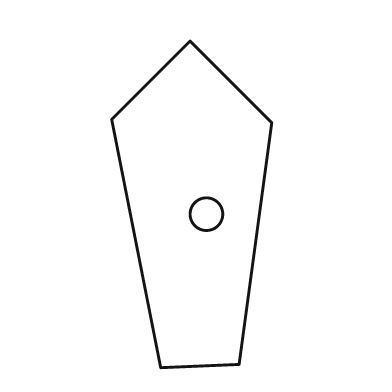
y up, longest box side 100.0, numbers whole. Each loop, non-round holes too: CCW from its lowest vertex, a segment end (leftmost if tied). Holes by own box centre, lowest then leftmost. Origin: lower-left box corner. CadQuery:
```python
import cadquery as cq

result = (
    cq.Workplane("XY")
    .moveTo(15.0, 0.0)
    .lineTo(39.0, 1.0)
    .lineTo(49.0, 75.0)
    .lineTo(24.0, 100.0)
    .lineTo(0.0, 76.0)
    .close()
    .moveTo(29.0, 47.0)
    .circle(5.0)
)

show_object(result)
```